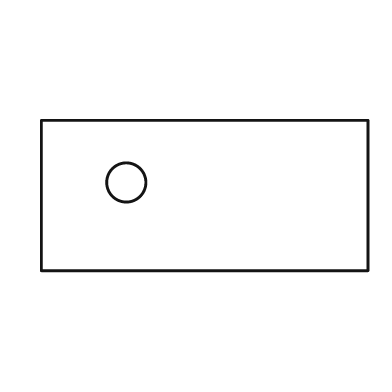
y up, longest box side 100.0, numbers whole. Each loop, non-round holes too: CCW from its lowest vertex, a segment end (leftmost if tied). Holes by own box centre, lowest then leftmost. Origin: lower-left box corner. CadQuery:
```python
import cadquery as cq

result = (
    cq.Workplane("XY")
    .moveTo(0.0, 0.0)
    .lineTo(100.0, 0.0)
    .lineTo(100.0, 46.0)
    .lineTo(0.0, 46.0)
    .close()
    .moveTo(26.0, 27.0)
    .circle(6.0)
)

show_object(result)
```